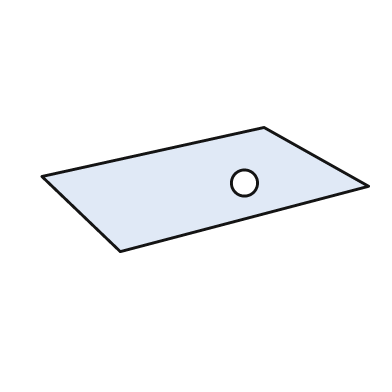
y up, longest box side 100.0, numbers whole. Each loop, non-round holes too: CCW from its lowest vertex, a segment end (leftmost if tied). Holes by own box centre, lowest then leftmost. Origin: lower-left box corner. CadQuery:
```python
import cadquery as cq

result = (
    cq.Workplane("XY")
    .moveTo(24.0, 0.0)
    .lineTo(100.0, 20.0)
    .lineTo(68.0, 38.0)
    .lineTo(0.0, 23.0)
    .close()
    .moveTo(62.0, 21.0)
    .circle(4.0)
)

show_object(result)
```